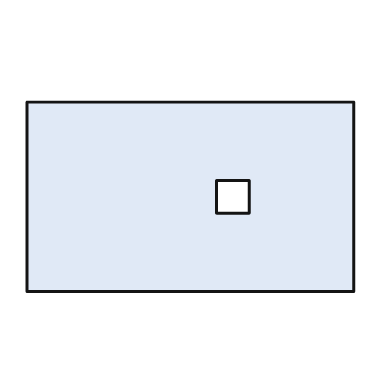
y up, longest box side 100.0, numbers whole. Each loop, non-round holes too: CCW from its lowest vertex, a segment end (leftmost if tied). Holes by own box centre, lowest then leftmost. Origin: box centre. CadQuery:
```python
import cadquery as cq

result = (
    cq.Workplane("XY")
    .moveTo(-50.0, -29.0)
    .lineTo(50.0, -29.0)
    .lineTo(50.0, 29.0)
    .lineTo(-50.0, 29.0)
    .close()
    .moveTo(8.0, -5.0)
    .lineTo(18.0, -5.0)
    .lineTo(18.0, 5.0)
    .lineTo(8.0, 5.0)
    .close()
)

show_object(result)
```